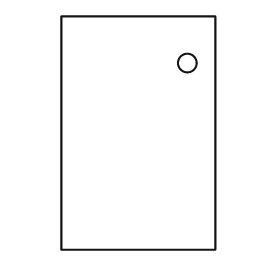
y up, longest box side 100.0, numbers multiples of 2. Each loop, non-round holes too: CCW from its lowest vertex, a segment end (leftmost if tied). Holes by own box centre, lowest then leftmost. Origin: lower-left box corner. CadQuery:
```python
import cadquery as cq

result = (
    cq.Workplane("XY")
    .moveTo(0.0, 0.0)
    .lineTo(66.0, 0.0)
    .lineTo(66.0, 100.0)
    .lineTo(0.0, 100.0)
    .close()
    .moveTo(54.0, 80.0)
    .circle(4.0)
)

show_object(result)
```